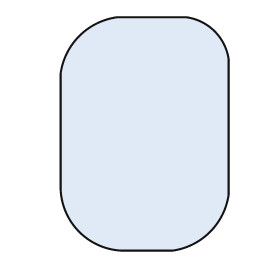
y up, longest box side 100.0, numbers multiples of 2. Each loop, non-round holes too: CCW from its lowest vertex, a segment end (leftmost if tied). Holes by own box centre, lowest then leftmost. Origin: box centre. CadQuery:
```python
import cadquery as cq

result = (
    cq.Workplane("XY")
    .moveTo(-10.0, -50.0)
    .lineTo(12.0, -50.0)
    .threePointArc((28.0, -42.0), (36.0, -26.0))
    .lineTo(36.0, 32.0)
    .threePointArc((30.0, 44.0), (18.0, 50.0))
    .lineTo(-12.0, 50.0)
    .threePointArc((-28.0, 42.0), (-36.0, 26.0))
    .lineTo(-36.0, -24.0)
    .threePointArc((-28.0, -42.0), (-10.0, -50.0))
    .close()
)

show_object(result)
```